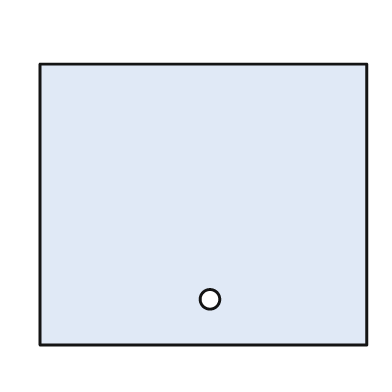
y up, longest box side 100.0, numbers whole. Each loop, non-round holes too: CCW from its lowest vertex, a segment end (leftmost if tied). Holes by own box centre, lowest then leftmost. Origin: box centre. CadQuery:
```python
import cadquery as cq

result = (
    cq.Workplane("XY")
    .moveTo(-50.0, -43.0)
    .lineTo(50.0, -43.0)
    .lineTo(50.0, 43.0)
    .lineTo(-50.0, 43.0)
    .close()
    .moveTo(2.0, -29.0)
    .circle(3.0)
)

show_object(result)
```